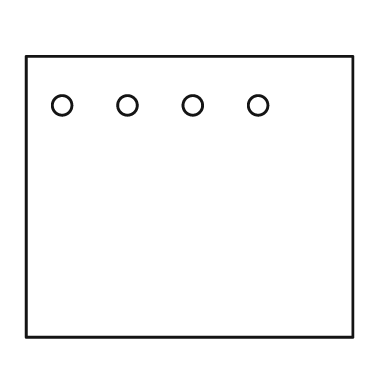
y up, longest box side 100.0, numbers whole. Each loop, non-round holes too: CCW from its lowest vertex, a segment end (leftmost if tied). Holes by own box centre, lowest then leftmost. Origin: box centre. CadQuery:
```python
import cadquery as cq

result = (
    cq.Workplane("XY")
    .moveTo(-50.0, -43.0)
    .lineTo(50.0, -43.0)
    .lineTo(50.0, 43.0)
    .lineTo(-50.0, 43.0)
    .close()
    .moveTo(-39.0, 28.0)
    .circle(3.0)
    .moveTo(-19.0, 28.0)
    .circle(3.0)
    .moveTo(1.0, 28.0)
    .circle(3.0)
    .moveTo(21.0, 28.0)
    .circle(3.0)
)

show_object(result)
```